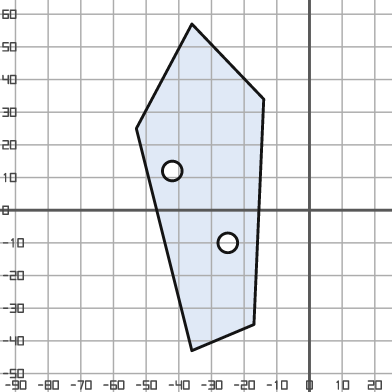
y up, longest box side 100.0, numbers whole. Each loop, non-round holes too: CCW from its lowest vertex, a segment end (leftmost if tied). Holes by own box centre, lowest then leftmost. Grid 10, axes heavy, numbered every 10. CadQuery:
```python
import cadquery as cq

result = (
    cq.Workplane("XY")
    .moveTo(-36.0, -43.0)
    .lineTo(-17.0, -35.0)
    .lineTo(-14.0, 34.0)
    .lineTo(-36.0, 57.0)
    .lineTo(-53.0, 25.0)
    .close()
    .moveTo(-25.0, -10.0)
    .circle(3.0)
    .moveTo(-42.0, 12.0)
    .circle(3.0)
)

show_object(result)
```